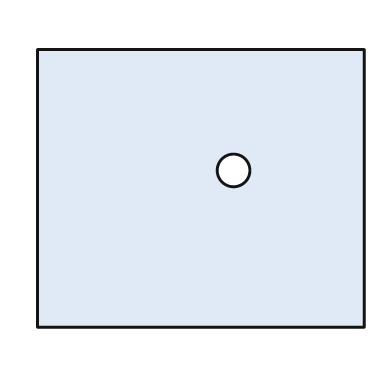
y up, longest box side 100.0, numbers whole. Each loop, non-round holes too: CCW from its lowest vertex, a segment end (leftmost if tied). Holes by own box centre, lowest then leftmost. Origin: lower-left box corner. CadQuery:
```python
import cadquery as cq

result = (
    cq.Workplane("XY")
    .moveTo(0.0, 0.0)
    .lineTo(100.0, 0.0)
    .lineTo(100.0, 85.0)
    .lineTo(0.0, 85.0)
    .close()
    .moveTo(60.0, 48.0)
    .circle(5.0)
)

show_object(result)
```